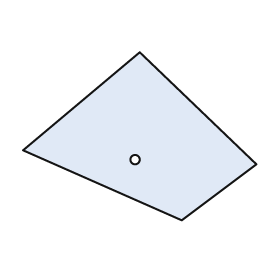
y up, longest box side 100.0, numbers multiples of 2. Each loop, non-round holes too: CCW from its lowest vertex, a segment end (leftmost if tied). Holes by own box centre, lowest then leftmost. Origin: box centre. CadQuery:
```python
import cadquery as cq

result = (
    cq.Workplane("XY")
    .moveTo(18.0, -36.0)
    .lineTo(50.0, -12.0)
    .lineTo(0.0, 36.0)
    .lineTo(-50.0, -6.0)
    .close()
    .moveTo(-2.0, -10.0)
    .circle(2.0)
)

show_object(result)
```